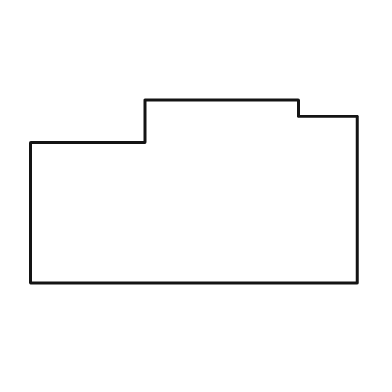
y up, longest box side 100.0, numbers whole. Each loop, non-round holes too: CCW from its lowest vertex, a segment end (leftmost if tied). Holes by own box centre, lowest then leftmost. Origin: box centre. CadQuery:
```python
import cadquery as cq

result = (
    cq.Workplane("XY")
    .moveTo(-50.0, -28.0)
    .lineTo(50.0, -28.0)
    .lineTo(50.0, 23.0)
    .lineTo(32.0, 23.0)
    .lineTo(32.0, 28.0)
    .lineTo(-15.0, 28.0)
    .lineTo(-15.0, 15.0)
    .lineTo(-50.0, 15.0)
    .close()
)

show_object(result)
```